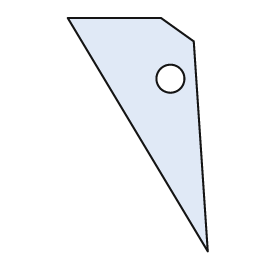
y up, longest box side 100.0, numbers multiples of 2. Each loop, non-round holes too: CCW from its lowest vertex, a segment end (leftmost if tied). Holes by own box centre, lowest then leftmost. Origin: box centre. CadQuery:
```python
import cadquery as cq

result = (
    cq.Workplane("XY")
    .moveTo(30.0, -50.0)
    .lineTo(24.0, 40.0)
    .lineTo(10.0, 50.0)
    .lineTo(-30.0, 50.0)
    .close()
    .moveTo(14.0, 24.0)
    .circle(6.0)
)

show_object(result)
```